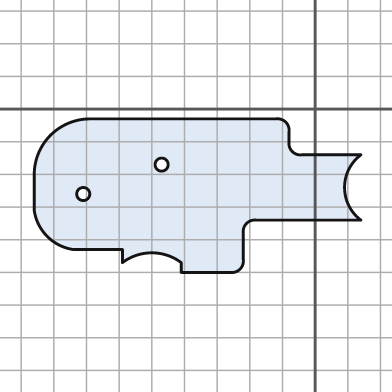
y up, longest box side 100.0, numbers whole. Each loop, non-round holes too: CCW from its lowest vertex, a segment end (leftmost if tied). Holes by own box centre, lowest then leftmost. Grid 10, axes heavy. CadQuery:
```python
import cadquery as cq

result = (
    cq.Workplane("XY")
    .moveTo(-41.0, -50.0)
    .lineTo(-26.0, -50.0)
    .threePointArc((-23.0, -49.0), (-22.0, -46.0))
    .lineTo(-22.0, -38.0)
    .threePointArc((-21.0, -35.0), (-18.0, -34.0))
    .lineTo(14.0, -34.0)
    .threePointArc((9.0, -24.0), (14.0, -14.0))
    .lineTo(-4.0, -14.0)
    .threePointArc((-7.0, -13.0), (-8.0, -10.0))
    .lineTo(-8.0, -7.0)
    .threePointArc((-9.0, -4.0), (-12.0, -3.0))
    .lineTo(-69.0, -3.0)
    .threePointArc((-81.0, -8.0), (-86.0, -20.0))
    .lineTo(-86.0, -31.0)
    .threePointArc((-82.0, -39.0), (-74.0, -43.0))
    .lineTo(-59.0, -43.0)
    .lineTo(-59.0, -47.0)
    .threePointArc((-50.0, -44.0), (-41.0, -47.0))
    .close()
    .moveTo(-71.0, -26.0)
    .circle(2.0)
    .moveTo(-47.0, -17.0)
    .circle(2.0)
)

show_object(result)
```